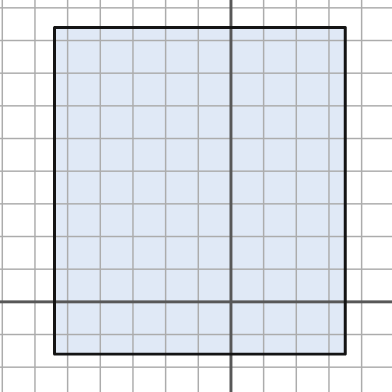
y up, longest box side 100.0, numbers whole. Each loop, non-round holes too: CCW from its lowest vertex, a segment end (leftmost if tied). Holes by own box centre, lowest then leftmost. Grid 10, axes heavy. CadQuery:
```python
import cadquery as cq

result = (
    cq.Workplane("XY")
    .moveTo(-54.0, -16.0)
    .lineTo(35.0, -16.0)
    .lineTo(35.0, 84.0)
    .lineTo(-54.0, 84.0)
    .close()
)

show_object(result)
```